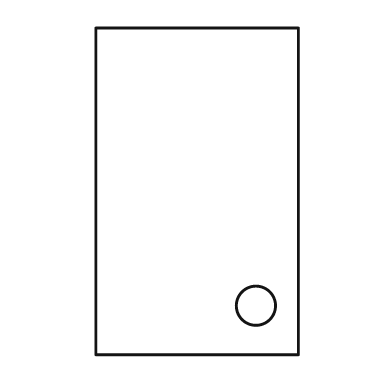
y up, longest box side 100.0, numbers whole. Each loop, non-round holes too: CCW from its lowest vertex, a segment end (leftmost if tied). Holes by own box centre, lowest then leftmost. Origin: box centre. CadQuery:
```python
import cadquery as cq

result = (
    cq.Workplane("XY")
    .moveTo(-31.0, -50.0)
    .lineTo(31.0, -50.0)
    .lineTo(31.0, 50.0)
    .lineTo(-31.0, 50.0)
    .close()
    .moveTo(18.0, -35.0)
    .circle(6.0)
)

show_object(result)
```